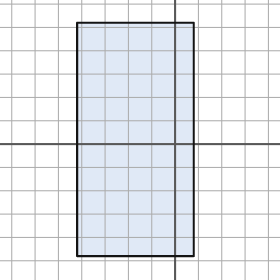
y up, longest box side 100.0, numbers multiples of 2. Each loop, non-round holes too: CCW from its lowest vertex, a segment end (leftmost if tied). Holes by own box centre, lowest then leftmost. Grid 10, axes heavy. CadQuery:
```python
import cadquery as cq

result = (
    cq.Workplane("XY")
    .moveTo(-42.0, -48.0)
    .lineTo(8.0, -48.0)
    .lineTo(8.0, 52.0)
    .lineTo(-42.0, 52.0)
    .close()
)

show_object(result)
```